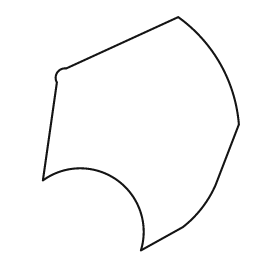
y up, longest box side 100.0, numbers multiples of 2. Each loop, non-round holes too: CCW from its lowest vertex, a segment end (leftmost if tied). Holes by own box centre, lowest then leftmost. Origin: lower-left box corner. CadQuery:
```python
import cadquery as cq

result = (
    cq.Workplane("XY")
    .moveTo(42.0, 0.0)
    .lineTo(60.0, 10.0)
    .threePointArc((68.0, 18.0), (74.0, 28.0))
    .lineTo(84.0, 54.0)
    .threePointArc((76.0, 80.0), (58.0, 100.0))
    .lineTo(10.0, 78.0)
    .threePointArc((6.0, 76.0), (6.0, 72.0))
    .lineTo(0.0, 30.0)
    .threePointArc((32.0, 30.0), (42.0, 0.0))
    .close()
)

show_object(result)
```